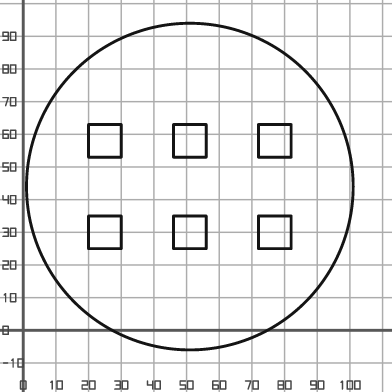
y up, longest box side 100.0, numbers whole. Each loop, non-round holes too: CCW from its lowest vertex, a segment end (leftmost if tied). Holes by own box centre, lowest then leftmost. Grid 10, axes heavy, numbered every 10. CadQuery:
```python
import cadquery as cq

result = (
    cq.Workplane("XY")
    .moveTo(51.0, 44.0)
    .circle(50.0)
    .moveTo(20.0, 25.0)
    .lineTo(30.0, 25.0)
    .lineTo(30.0, 35.0)
    .lineTo(20.0, 35.0)
    .close()
    .moveTo(46.0, 25.0)
    .lineTo(56.0, 25.0)
    .lineTo(56.0, 35.0)
    .lineTo(46.0, 35.0)
    .close()
    .moveTo(72.0, 25.0)
    .lineTo(82.0, 25.0)
    .lineTo(82.0, 35.0)
    .lineTo(72.0, 35.0)
    .close()
    .moveTo(20.0, 53.0)
    .lineTo(30.0, 53.0)
    .lineTo(30.0, 63.0)
    .lineTo(20.0, 63.0)
    .close()
    .moveTo(46.0, 53.0)
    .lineTo(56.0, 53.0)
    .lineTo(56.0, 63.0)
    .lineTo(46.0, 63.0)
    .close()
    .moveTo(72.0, 53.0)
    .lineTo(82.0, 53.0)
    .lineTo(82.0, 63.0)
    .lineTo(72.0, 63.0)
    .close()
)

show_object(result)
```